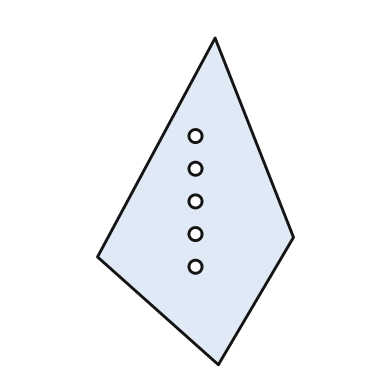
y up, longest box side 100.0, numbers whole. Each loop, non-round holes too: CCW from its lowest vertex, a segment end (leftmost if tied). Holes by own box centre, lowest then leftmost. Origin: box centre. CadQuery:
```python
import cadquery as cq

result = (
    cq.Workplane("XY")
    .moveTo(7.0, -50.0)
    .lineTo(30.0, -11.0)
    .lineTo(6.0, 50.0)
    .lineTo(-30.0, -17.0)
    .close()
    .moveTo(0.0, -20.0)
    .circle(2.0)
    .moveTo(0.0, -10.0)
    .circle(2.0)
    .moveTo(0.0, 0.0)
    .circle(2.0)
    .moveTo(0.0, 10.0)
    .circle(2.0)
    .moveTo(0.0, 20.0)
    .circle(2.0)
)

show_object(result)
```